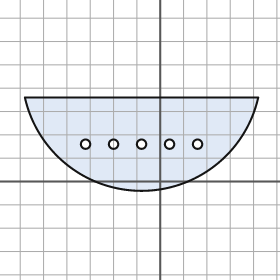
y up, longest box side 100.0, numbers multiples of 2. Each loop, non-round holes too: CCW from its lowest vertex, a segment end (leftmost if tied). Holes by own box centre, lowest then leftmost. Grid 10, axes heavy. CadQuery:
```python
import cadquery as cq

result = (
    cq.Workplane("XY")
    .moveTo(-58.0, 36.0)
    .threePointArc((-8.0, -4.0), (42.0, 36.0))
    .close()
    .moveTo(-32.0, 16.0)
    .circle(2.0)
    .moveTo(-20.0, 16.0)
    .circle(2.0)
    .moveTo(-8.0, 16.0)
    .circle(2.0)
    .moveTo(4.0, 16.0)
    .circle(2.0)
    .moveTo(16.0, 16.0)
    .circle(2.0)
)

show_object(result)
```